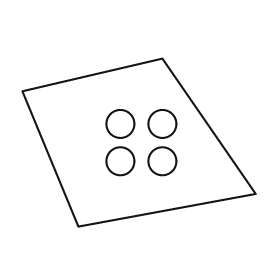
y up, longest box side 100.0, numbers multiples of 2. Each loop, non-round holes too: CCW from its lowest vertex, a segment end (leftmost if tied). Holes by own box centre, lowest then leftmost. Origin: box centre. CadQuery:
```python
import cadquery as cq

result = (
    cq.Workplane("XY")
    .moveTo(-26.0, -36.0)
    .lineTo(50.0, -22.0)
    .lineTo(10.0, 36.0)
    .lineTo(-50.0, 22.0)
    .close()
    .moveTo(-8.0, -8.0)
    .circle(6.0)
    .moveTo(10.0, -8.0)
    .circle(6.0)
    .moveTo(-8.0, 8.0)
    .circle(6.0)
    .moveTo(10.0, 8.0)
    .circle(6.0)
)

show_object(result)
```